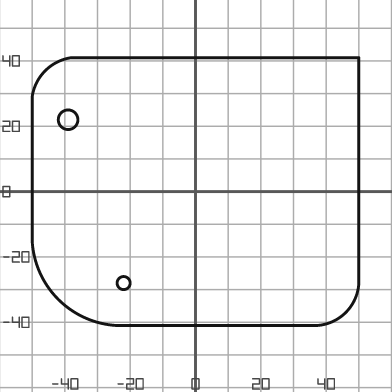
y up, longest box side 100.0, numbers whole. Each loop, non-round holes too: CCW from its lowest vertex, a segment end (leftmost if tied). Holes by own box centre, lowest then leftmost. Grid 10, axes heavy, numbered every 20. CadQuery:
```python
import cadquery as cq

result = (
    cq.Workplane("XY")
    .moveTo(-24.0, -41.0)
    .lineTo(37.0, -41.0)
    .threePointArc((46.0, -37.0), (50.0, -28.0))
    .lineTo(50.0, 41.0)
    .lineTo(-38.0, 41.0)
    .threePointArc((-46.0, 37.0), (-50.0, 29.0))
    .lineTo(-50.0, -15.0)
    .threePointArc((-42.0, -33.0), (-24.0, -41.0))
    .close()
    .moveTo(-22.0, -28.0)
    .circle(2.0)
    .moveTo(-39.0, 22.0)
    .circle(3.0)
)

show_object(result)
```